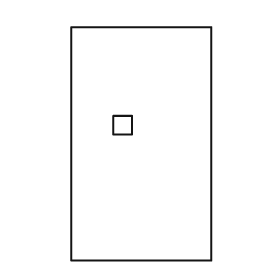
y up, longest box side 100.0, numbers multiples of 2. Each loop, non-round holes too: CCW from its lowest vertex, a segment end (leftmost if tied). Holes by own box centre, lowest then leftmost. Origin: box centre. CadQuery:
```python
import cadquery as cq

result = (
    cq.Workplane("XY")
    .moveTo(-30.0, -50.0)
    .lineTo(30.0, -50.0)
    .lineTo(30.0, 50.0)
    .lineTo(-30.0, 50.0)
    .close()
    .moveTo(-12.0, 4.0)
    .lineTo(-4.0, 4.0)
    .lineTo(-4.0, 12.0)
    .lineTo(-12.0, 12.0)
    .close()
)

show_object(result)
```